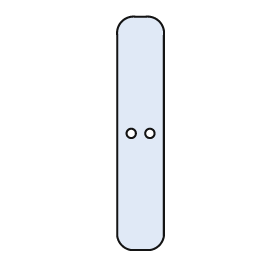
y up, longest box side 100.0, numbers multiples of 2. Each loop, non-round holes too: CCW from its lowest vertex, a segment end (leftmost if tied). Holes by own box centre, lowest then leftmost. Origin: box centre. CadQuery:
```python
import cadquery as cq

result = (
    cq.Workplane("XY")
    .moveTo(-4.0, -50.0)
    .lineTo(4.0, -50.0)
    .threePointArc((8.0, -48.0), (10.0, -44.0))
    .lineTo(10.0, 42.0)
    .threePointArc((8.0, 48.0), (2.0, 50.0))
    .lineTo(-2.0, 50.0)
    .threePointArc((-8.0, 48.0), (-10.0, 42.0))
    .lineTo(-10.0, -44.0)
    .threePointArc((-8.0, -48.0), (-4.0, -50.0))
    .close()
    .moveTo(-4.0, 0.0)
    .circle(2.0)
    .moveTo(4.0, 0.0)
    .circle(2.0)
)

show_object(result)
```